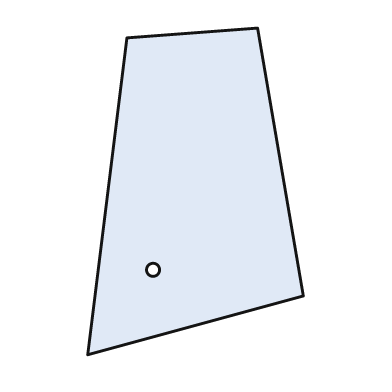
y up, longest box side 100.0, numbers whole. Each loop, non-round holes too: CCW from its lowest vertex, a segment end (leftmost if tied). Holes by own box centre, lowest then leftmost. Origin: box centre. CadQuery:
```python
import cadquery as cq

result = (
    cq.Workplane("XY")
    .moveTo(-33.0, -50.0)
    .lineTo(33.0, -32.0)
    .lineTo(19.0, 50.0)
    .lineTo(-21.0, 47.0)
    .close()
    .moveTo(-13.0, -24.0)
    .circle(2.0)
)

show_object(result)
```